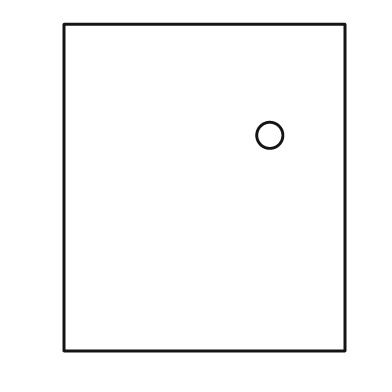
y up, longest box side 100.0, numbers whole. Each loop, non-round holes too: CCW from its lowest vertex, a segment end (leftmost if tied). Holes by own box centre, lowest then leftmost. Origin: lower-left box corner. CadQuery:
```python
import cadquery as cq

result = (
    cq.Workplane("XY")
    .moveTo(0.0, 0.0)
    .lineTo(86.0, 0.0)
    .lineTo(86.0, 100.0)
    .lineTo(0.0, 100.0)
    .close()
    .moveTo(63.0, 66.0)
    .circle(4.0)
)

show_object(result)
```